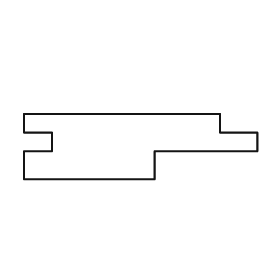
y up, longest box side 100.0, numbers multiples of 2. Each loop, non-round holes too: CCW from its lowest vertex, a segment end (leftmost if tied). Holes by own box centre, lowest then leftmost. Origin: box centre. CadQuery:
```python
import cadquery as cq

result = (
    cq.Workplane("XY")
    .moveTo(-50.0, -14.0)
    .lineTo(6.0, -14.0)
    .lineTo(6.0, -2.0)
    .lineTo(50.0, -2.0)
    .lineTo(50.0, 6.0)
    .lineTo(34.0, 6.0)
    .lineTo(34.0, 14.0)
    .lineTo(-50.0, 14.0)
    .lineTo(-50.0, 6.0)
    .lineTo(-38.0, 6.0)
    .lineTo(-38.0, -2.0)
    .lineTo(-50.0, -2.0)
    .close()
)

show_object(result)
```